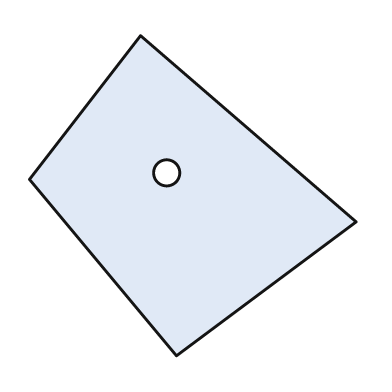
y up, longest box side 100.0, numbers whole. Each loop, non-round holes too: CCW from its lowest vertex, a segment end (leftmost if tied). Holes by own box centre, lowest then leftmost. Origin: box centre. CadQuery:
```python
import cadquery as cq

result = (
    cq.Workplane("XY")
    .moveTo(-5.0, -49.0)
    .lineTo(50.0, -8.0)
    .lineTo(-16.0, 49.0)
    .lineTo(-50.0, 5.0)
    .close()
    .moveTo(-8.0, 7.0)
    .circle(4.0)
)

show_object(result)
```